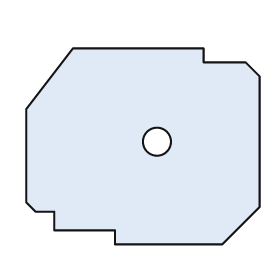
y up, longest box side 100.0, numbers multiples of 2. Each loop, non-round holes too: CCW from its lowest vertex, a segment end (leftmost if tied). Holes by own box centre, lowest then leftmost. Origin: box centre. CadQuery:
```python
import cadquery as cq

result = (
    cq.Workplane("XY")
    .moveTo(-12.0, -42.0)
    .lineTo(34.0, -42.0)
    .lineTo(50.0, -26.0)
    .lineTo(50.0, 30.0)
    .lineTo(44.0, 36.0)
    .lineTo(26.0, 36.0)
    .lineTo(26.0, 42.0)
    .lineTo(-30.0, 42.0)
    .lineTo(-50.0, 16.0)
    .lineTo(-50.0, -24.0)
    .lineTo(-46.0, -28.0)
    .lineTo(-38.0, -28.0)
    .lineTo(-38.0, -36.0)
    .lineTo(-12.0, -36.0)
    .close()
    .moveTo(6.0, 2.0)
    .circle(6.0)
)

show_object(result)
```